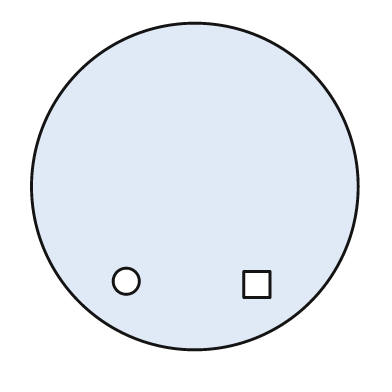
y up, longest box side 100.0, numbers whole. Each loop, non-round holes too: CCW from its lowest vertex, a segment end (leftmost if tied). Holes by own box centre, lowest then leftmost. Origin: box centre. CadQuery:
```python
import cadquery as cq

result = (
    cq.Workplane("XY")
    .moveTo(0.0, 0.0)
    .circle(50.0)
    .moveTo(15.0, -34.0)
    .lineTo(23.0, -34.0)
    .lineTo(23.0, -26.0)
    .lineTo(15.0, -26.0)
    .close()
    .moveTo(-21.0, -29.0)
    .circle(4.0)
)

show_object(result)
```